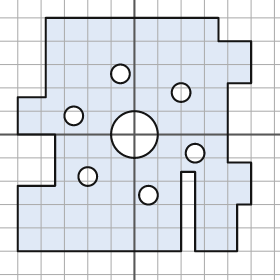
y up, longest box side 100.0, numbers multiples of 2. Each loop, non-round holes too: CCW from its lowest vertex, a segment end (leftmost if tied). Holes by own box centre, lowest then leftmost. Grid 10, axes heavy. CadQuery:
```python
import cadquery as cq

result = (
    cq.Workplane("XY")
    .moveTo(-50.0, -50.0)
    .lineTo(20.0, -50.0)
    .lineTo(20.0, -16.0)
    .lineTo(26.0, -16.0)
    .lineTo(26.0, -50.0)
    .lineTo(44.0, -50.0)
    .lineTo(44.0, -30.0)
    .lineTo(50.0, -30.0)
    .lineTo(50.0, -12.0)
    .lineTo(40.0, -12.0)
    .lineTo(40.0, 22.0)
    .lineTo(50.0, 22.0)
    .lineTo(50.0, 40.0)
    .lineTo(36.0, 40.0)
    .lineTo(36.0, 50.0)
    .lineTo(-38.0, 50.0)
    .lineTo(-38.0, 16.0)
    .lineTo(-50.0, 16.0)
    .lineTo(-50.0, 0.0)
    .lineTo(-34.0, 0.0)
    .lineTo(-34.0, -22.0)
    .lineTo(-50.0, -22.0)
    .close()
    .moveTo(6.0, -26.0)
    .circle(4.0)
    .moveTo(-20.0, -18.0)
    .circle(4.0)
    .moveTo(26.0, -8.0)
    .circle(4.0)
    .moveTo(0.0, 0.0)
    .circle(10.0)
    .moveTo(-26.0, 8.0)
    .circle(4.0)
    .moveTo(20.0, 18.0)
    .circle(4.0)
    .moveTo(-6.0, 26.0)
    .circle(4.0)
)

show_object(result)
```